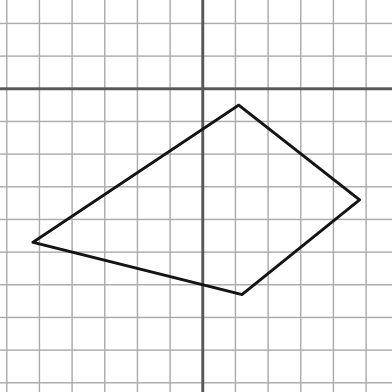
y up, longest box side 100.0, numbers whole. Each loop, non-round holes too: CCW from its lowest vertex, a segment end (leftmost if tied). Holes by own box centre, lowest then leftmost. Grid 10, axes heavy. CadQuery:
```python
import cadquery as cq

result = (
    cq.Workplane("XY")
    .moveTo(12.0, -63.0)
    .lineTo(48.0, -34.0)
    .lineTo(11.0, -5.0)
    .lineTo(-52.0, -47.0)
    .close()
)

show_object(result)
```